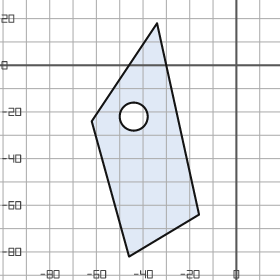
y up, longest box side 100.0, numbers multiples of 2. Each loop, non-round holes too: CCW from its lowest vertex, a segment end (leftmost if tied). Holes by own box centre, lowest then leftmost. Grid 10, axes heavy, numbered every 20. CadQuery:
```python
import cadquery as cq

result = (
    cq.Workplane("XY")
    .moveTo(-46.0, -82.0)
    .lineTo(-16.0, -64.0)
    .lineTo(-34.0, 18.0)
    .lineTo(-62.0, -24.0)
    .close()
    .moveTo(-44.0, -22.0)
    .circle(6.0)
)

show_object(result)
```